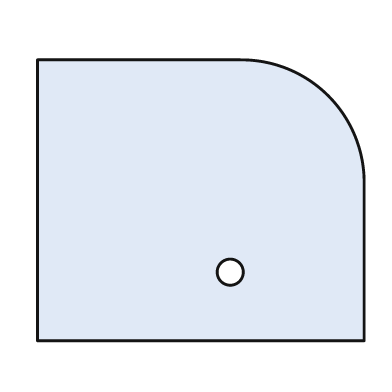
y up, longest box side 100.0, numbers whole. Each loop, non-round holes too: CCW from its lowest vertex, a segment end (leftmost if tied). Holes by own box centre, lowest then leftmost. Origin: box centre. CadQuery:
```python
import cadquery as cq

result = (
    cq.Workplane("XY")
    .moveTo(-50.0, -43.0)
    .lineTo(50.0, -43.0)
    .lineTo(50.0, 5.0)
    .threePointArc((39.0, 32.0), (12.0, 43.0))
    .lineTo(-50.0, 43.0)
    .close()
    .moveTo(9.0, -22.0)
    .circle(4.0)
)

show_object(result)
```